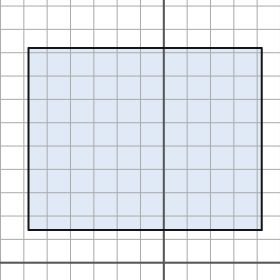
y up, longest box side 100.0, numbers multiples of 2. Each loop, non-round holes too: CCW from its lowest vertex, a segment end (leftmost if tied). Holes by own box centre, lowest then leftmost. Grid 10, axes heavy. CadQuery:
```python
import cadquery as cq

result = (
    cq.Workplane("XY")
    .moveTo(-58.0, 14.0)
    .lineTo(42.0, 14.0)
    .lineTo(42.0, 92.0)
    .lineTo(-58.0, 92.0)
    .close()
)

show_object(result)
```